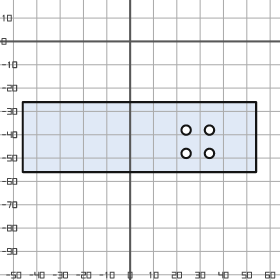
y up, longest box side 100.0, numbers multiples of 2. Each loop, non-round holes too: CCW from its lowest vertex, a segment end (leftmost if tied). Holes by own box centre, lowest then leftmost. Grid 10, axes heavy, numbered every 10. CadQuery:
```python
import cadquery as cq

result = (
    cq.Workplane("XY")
    .moveTo(-46.0, -56.0)
    .lineTo(54.0, -56.0)
    .lineTo(54.0, -26.0)
    .lineTo(-46.0, -26.0)
    .close()
    .moveTo(24.0, -48.0)
    .circle(2.0)
    .moveTo(34.0, -48.0)
    .circle(2.0)
    .moveTo(24.0, -38.0)
    .circle(2.0)
    .moveTo(34.0, -38.0)
    .circle(2.0)
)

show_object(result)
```